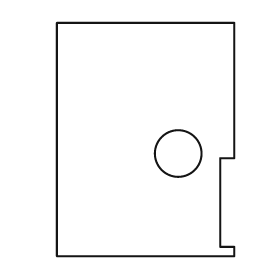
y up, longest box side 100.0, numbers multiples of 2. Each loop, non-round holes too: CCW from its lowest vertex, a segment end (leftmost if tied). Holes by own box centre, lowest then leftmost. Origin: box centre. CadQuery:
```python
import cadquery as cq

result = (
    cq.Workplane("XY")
    .moveTo(-38.0, -50.0)
    .lineTo(38.0, -50.0)
    .lineTo(38.0, -46.0)
    .lineTo(32.0, -46.0)
    .lineTo(32.0, -8.0)
    .lineTo(38.0, -8.0)
    .lineTo(38.0, 50.0)
    .lineTo(-38.0, 50.0)
    .close()
    .moveTo(14.0, -6.0)
    .circle(10.0)
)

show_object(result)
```